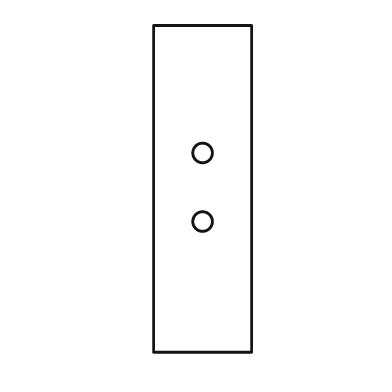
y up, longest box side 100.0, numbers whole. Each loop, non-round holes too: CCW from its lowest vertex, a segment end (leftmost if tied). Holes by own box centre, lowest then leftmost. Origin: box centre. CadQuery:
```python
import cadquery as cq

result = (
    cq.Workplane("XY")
    .moveTo(-15.0, -50.0)
    .lineTo(15.0, -50.0)
    .lineTo(15.0, 50.0)
    .lineTo(-15.0, 50.0)
    .close()
    .moveTo(0.0, -10.0)
    .circle(3.0)
    .moveTo(0.0, 11.0)
    .circle(3.0)
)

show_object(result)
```